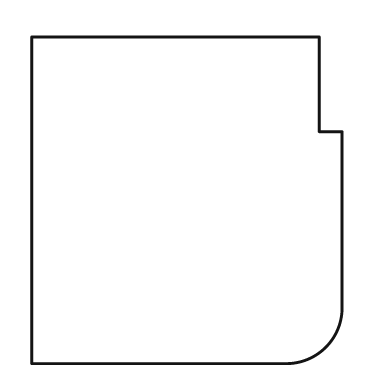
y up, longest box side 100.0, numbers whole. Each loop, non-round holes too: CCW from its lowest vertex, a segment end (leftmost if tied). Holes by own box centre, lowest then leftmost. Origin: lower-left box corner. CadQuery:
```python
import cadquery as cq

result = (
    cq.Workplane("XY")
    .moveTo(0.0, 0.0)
    .lineTo(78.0, 0.0)
    .threePointArc((90.0, 5.0), (95.0, 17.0))
    .lineTo(95.0, 71.0)
    .lineTo(88.0, 71.0)
    .lineTo(88.0, 100.0)
    .lineTo(0.0, 100.0)
    .close()
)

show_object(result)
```